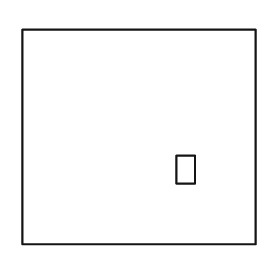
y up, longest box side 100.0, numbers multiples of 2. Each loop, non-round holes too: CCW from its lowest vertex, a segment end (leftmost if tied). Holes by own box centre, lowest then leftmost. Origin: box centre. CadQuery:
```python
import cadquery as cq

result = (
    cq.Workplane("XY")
    .moveTo(-50.0, -46.0)
    .lineTo(50.0, -46.0)
    .lineTo(50.0, 46.0)
    .lineTo(-50.0, 46.0)
    .close()
    .moveTo(16.0, -20.0)
    .lineTo(24.0, -20.0)
    .lineTo(24.0, -8.0)
    .lineTo(16.0, -8.0)
    .close()
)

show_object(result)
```